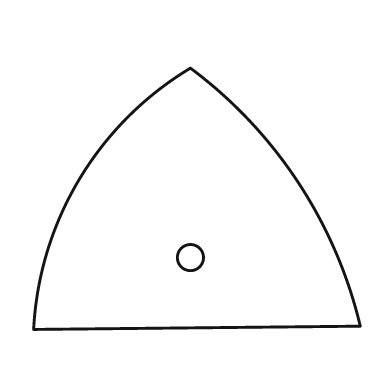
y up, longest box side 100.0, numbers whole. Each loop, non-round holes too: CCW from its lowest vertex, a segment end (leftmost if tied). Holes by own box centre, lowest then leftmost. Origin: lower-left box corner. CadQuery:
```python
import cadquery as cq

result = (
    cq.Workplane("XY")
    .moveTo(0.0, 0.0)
    .lineTo(100.0, 1.0)
    .threePointArc((81.0, 45.0), (48.0, 80.0))
    .threePointArc((14.0, 46.0), (0.0, 0.0))
    .close()
    .moveTo(48.0, 22.0)
    .circle(4.0)
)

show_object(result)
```